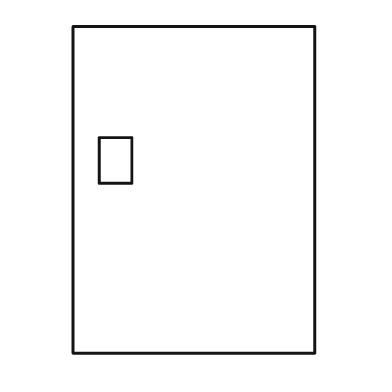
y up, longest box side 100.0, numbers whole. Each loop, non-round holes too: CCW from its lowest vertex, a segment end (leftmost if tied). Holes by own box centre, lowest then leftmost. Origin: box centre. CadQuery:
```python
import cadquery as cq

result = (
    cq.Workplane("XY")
    .moveTo(-37.0, -50.0)
    .lineTo(37.0, -50.0)
    .lineTo(37.0, 50.0)
    .lineTo(-37.0, 50.0)
    .close()
    .moveTo(-29.0, 2.0)
    .lineTo(-19.0, 2.0)
    .lineTo(-19.0, 16.0)
    .lineTo(-29.0, 16.0)
    .close()
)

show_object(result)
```